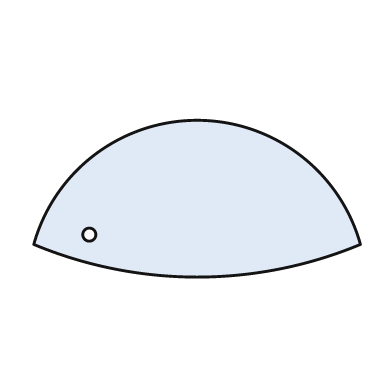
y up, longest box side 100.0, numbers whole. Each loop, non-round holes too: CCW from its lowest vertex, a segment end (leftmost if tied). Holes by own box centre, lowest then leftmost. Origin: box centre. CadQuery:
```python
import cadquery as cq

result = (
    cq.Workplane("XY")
    .moveTo(-50.0, -14.0)
    .threePointArc((0.0, -24.0), (50.0, -14.0))
    .threePointArc((0.0, 24.0), (-50.0, -14.0))
    .close()
    .moveTo(-33.0, -11.0)
    .circle(2.0)
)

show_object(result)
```